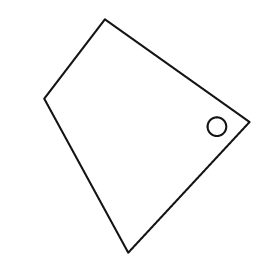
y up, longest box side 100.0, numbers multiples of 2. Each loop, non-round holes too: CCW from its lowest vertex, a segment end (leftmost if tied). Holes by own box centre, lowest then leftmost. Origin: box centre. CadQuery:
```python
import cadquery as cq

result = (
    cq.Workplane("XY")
    .moveTo(-8.0, -50.0)
    .lineTo(44.0, 6.0)
    .lineTo(-18.0, 50.0)
    .lineTo(-44.0, 16.0)
    .close()
    .moveTo(30.0, 4.0)
    .circle(4.0)
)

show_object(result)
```